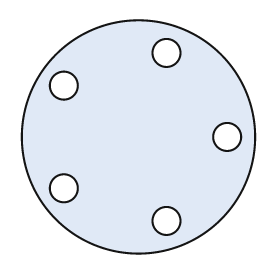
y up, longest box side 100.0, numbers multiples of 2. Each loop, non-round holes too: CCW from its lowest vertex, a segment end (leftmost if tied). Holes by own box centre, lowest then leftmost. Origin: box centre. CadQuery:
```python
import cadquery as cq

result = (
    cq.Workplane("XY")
    .moveTo(0.0, 0.0)
    .circle(50.0)
    .moveTo(12.0, -36.0)
    .circle(6.0)
    .moveTo(-32.0, -22.0)
    .circle(6.0)
    .moveTo(38.0, 0.0)
    .circle(6.0)
    .moveTo(-32.0, 22.0)
    .circle(6.0)
    .moveTo(12.0, 36.0)
    .circle(6.0)
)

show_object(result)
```